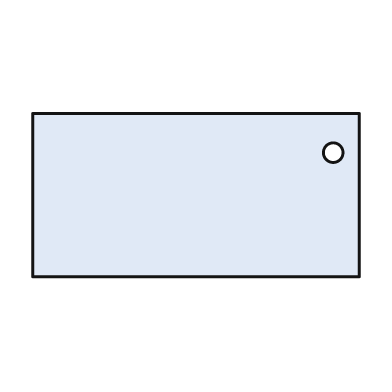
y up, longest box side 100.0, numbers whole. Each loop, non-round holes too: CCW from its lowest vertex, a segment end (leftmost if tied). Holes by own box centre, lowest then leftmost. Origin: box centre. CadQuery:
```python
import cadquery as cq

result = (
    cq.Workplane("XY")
    .moveTo(-50.0, -25.0)
    .lineTo(50.0, -25.0)
    .lineTo(50.0, 25.0)
    .lineTo(-50.0, 25.0)
    .close()
    .moveTo(42.0, 13.0)
    .circle(3.0)
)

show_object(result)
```